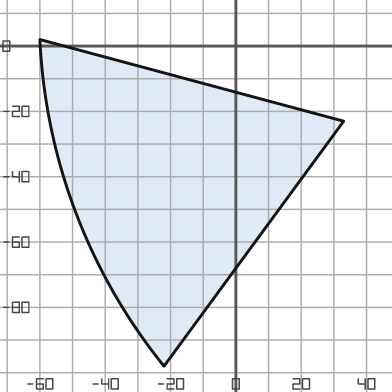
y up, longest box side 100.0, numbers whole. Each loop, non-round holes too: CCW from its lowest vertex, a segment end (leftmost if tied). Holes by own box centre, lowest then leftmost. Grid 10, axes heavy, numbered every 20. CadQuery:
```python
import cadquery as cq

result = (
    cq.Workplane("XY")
    .moveTo(-22.0, -98.0)
    .lineTo(33.0, -23.0)
    .lineTo(-60.0, 2.0)
    .threePointArc((-49.0, -51.0), (-22.0, -98.0))
    .close()
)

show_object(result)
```